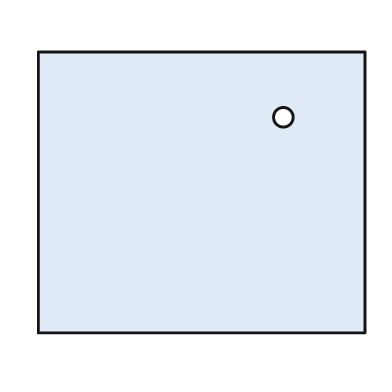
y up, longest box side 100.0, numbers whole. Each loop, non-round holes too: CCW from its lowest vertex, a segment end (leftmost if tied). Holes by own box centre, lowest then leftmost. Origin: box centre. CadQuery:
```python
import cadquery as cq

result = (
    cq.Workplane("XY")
    .moveTo(-50.0, -43.0)
    .lineTo(50.0, -43.0)
    .lineTo(50.0, 43.0)
    .lineTo(-50.0, 43.0)
    .close()
    .moveTo(25.0, 23.0)
    .circle(3.0)
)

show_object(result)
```